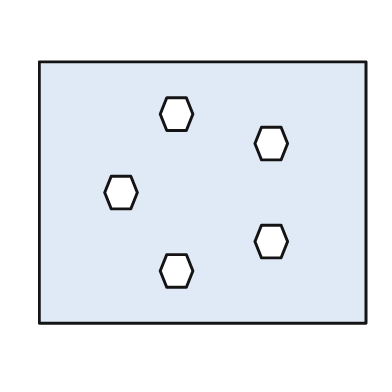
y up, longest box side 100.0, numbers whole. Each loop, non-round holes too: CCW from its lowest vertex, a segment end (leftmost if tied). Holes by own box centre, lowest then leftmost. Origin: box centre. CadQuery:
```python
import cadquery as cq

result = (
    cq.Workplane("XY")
    .moveTo(-50.0, -40.0)
    .lineTo(50.0, -40.0)
    .lineTo(50.0, 40.0)
    .lineTo(-50.0, 40.0)
    .close()
    .moveTo(-11.0, -29.0)
    .lineTo(-5.0, -29.0)
    .lineTo(-3.0, -24.0)
    .lineTo(-5.0, -19.0)
    .lineTo(-11.0, -19.0)
    .lineTo(-13.0, -24.0)
    .close()
    .moveTo(18.0, -20.0)
    .lineTo(24.0, -20.0)
    .lineTo(26.0, -15.0)
    .lineTo(24.0, -10.0)
    .lineTo(18.0, -10.0)
    .lineTo(16.0, -15.0)
    .close()
    .moveTo(-28.0, -5.0)
    .lineTo(-22.0, -5.0)
    .lineTo(-20.0, 0.0)
    .lineTo(-22.0, 5.0)
    .lineTo(-28.0, 5.0)
    .lineTo(-30.0, 0.0)
    .close()
    .moveTo(18.0, 10.0)
    .lineTo(24.0, 10.0)
    .lineTo(26.0, 15.0)
    .lineTo(24.0, 20.0)
    .lineTo(18.0, 20.0)
    .lineTo(16.0, 15.0)
    .close()
    .moveTo(-11.0, 19.0)
    .lineTo(-5.0, 19.0)
    .lineTo(-3.0, 24.0)
    .lineTo(-5.0, 29.0)
    .lineTo(-11.0, 29.0)
    .lineTo(-13.0, 24.0)
    .close()
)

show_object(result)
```